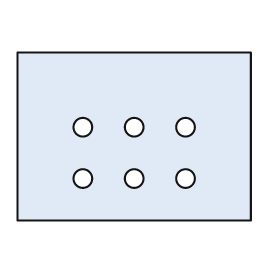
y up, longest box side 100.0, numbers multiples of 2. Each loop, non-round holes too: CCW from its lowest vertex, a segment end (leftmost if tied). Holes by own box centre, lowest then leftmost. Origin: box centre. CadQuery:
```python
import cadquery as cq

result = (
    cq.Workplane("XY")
    .moveTo(-50.0, -36.0)
    .lineTo(50.0, -36.0)
    .lineTo(50.0, 36.0)
    .lineTo(-50.0, 36.0)
    .close()
    .moveTo(-22.0, -18.0)
    .circle(4.0)
    .moveTo(0.0, -18.0)
    .circle(4.0)
    .moveTo(22.0, -18.0)
    .circle(4.0)
    .moveTo(-22.0, 4.0)
    .circle(4.0)
    .moveTo(0.0, 4.0)
    .circle(4.0)
    .moveTo(22.0, 4.0)
    .circle(4.0)
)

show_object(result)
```